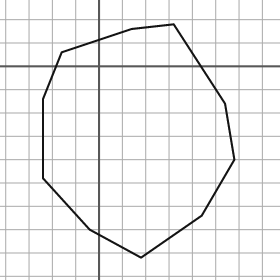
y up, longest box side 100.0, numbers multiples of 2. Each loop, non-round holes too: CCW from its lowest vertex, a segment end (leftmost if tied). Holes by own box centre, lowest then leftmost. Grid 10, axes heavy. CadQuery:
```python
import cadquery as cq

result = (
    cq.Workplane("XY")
    .moveTo(18.0, -82.0)
    .lineTo(44.0, -64.0)
    .lineTo(58.0, -40.0)
    .lineTo(54.0, -16.0)
    .lineTo(32.0, 18.0)
    .lineTo(14.0, 16.0)
    .lineTo(-16.0, 6.0)
    .lineTo(-24.0, -14.0)
    .lineTo(-24.0, -48.0)
    .lineTo(-4.0, -70.0)
    .close()
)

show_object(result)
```